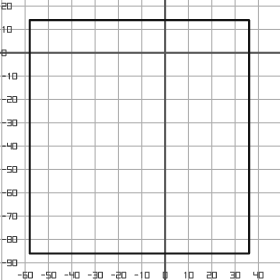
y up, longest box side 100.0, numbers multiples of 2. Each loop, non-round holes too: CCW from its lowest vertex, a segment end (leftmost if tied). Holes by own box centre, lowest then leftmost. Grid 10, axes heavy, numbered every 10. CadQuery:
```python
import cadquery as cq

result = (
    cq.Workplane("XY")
    .moveTo(-58.0, -86.0)
    .lineTo(36.0, -86.0)
    .lineTo(36.0, 14.0)
    .lineTo(-58.0, 14.0)
    .close()
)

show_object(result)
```